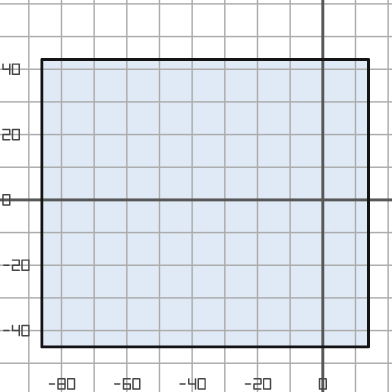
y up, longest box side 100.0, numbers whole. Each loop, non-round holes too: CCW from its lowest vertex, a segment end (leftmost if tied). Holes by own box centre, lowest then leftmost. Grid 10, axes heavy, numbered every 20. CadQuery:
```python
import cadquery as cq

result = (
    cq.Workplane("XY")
    .moveTo(-86.0, -45.0)
    .lineTo(14.0, -45.0)
    .lineTo(14.0, 43.0)
    .lineTo(-86.0, 43.0)
    .close()
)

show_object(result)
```